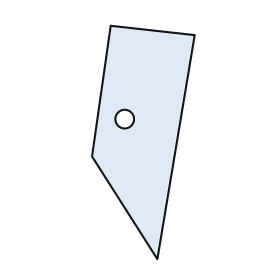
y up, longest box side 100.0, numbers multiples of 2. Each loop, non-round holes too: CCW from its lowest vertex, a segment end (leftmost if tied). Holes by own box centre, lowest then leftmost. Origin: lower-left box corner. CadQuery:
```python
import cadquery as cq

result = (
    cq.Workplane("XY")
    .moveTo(28.0, 0.0)
    .lineTo(44.0, 96.0)
    .lineTo(8.0, 100.0)
    .lineTo(0.0, 44.0)
    .close()
    .moveTo(14.0, 60.0)
    .circle(4.0)
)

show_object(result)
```